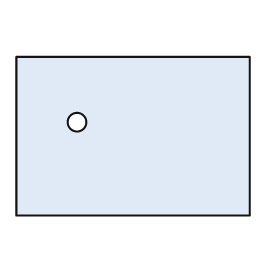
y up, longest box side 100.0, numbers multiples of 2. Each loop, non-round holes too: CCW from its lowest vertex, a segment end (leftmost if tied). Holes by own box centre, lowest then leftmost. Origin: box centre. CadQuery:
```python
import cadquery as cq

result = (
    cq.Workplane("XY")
    .moveTo(-50.0, -34.0)
    .lineTo(50.0, -34.0)
    .lineTo(50.0, 34.0)
    .lineTo(-50.0, 34.0)
    .close()
    .moveTo(-24.0, 6.0)
    .circle(4.0)
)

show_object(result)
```